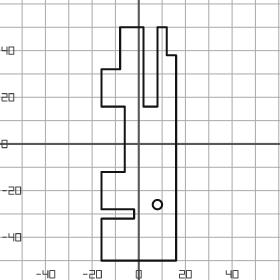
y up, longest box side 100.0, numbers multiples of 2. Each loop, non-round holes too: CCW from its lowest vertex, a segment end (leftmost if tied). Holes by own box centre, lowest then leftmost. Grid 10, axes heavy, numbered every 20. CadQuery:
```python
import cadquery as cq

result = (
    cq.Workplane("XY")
    .moveTo(-16.0, -50.0)
    .lineTo(16.0, -50.0)
    .lineTo(16.0, 38.0)
    .lineTo(12.0, 38.0)
    .lineTo(12.0, 50.0)
    .lineTo(8.0, 50.0)
    .lineTo(8.0, 16.0)
    .lineTo(2.0, 16.0)
    .lineTo(2.0, 50.0)
    .lineTo(-8.0, 50.0)
    .lineTo(-8.0, 32.0)
    .lineTo(-16.0, 32.0)
    .lineTo(-16.0, 16.0)
    .lineTo(-6.0, 16.0)
    .lineTo(-6.0, -12.0)
    .lineTo(-16.0, -12.0)
    .lineTo(-16.0, -28.0)
    .lineTo(-2.0, -28.0)
    .lineTo(-2.0, -32.0)
    .lineTo(-16.0, -32.0)
    .close()
    .moveTo(8.0, -26.0)
    .circle(2.0)
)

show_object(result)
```